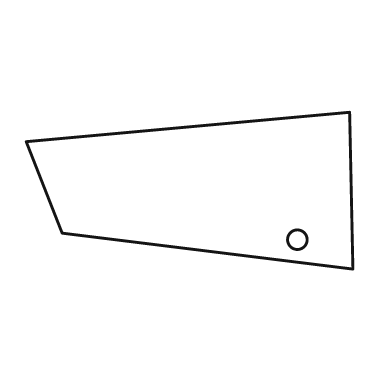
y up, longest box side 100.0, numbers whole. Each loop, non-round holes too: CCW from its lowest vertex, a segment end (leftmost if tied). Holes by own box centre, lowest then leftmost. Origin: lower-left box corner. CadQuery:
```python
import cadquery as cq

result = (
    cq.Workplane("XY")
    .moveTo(100.0, 0.0)
    .lineTo(99.0, 48.0)
    .lineTo(0.0, 39.0)
    .lineTo(11.0, 11.0)
    .close()
    .moveTo(83.0, 9.0)
    .circle(3.0)
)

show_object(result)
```